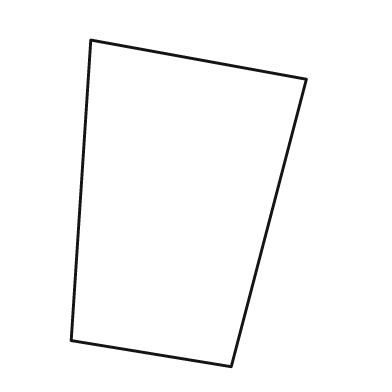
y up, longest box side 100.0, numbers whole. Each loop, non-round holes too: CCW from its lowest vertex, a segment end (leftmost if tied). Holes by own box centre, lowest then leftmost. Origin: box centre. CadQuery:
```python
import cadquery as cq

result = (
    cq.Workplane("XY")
    .moveTo(13.0, -50.0)
    .lineTo(36.0, 38.0)
    .lineTo(-30.0, 50.0)
    .lineTo(-36.0, -42.0)
    .close()
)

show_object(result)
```